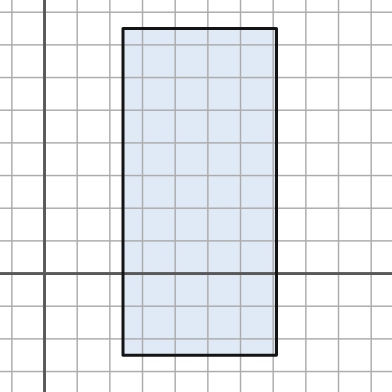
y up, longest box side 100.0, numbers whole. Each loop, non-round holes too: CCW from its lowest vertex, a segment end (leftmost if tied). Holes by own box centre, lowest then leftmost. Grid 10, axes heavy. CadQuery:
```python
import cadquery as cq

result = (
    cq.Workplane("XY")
    .moveTo(24.0, -25.0)
    .lineTo(71.0, -25.0)
    .lineTo(71.0, 75.0)
    .lineTo(24.0, 75.0)
    .close()
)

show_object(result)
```